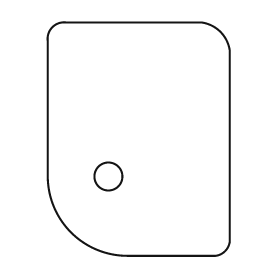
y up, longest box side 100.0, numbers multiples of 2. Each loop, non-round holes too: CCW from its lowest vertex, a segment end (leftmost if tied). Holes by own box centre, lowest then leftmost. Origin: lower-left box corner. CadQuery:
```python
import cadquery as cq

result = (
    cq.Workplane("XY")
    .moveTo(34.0, 0.0)
    .lineTo(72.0, 0.0)
    .threePointArc((76.0, 2.0), (78.0, 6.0))
    .lineTo(78.0, 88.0)
    .threePointArc((74.0, 96.0), (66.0, 100.0))
    .lineTo(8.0, 100.0)
    .threePointArc((2.0, 98.0), (0.0, 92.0))
    .lineTo(0.0, 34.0)
    .threePointArc((10.0, 10.0), (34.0, 0.0))
    .close()
    .moveTo(26.0, 34.0)
    .circle(6.0)
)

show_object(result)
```